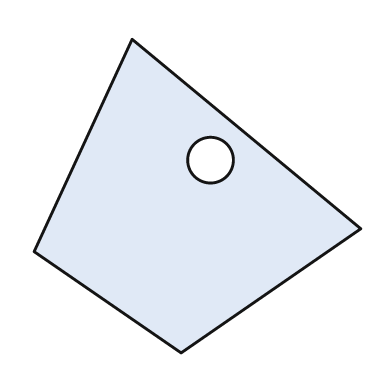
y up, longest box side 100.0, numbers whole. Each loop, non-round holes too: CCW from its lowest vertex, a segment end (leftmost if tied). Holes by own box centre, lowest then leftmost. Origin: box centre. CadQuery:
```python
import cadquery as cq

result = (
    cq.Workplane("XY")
    .moveTo(-5.0, -48.0)
    .lineTo(50.0, -10.0)
    .lineTo(-20.0, 48.0)
    .lineTo(-50.0, -17.0)
    .close()
    .moveTo(4.0, 11.0)
    .circle(7.0)
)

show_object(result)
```